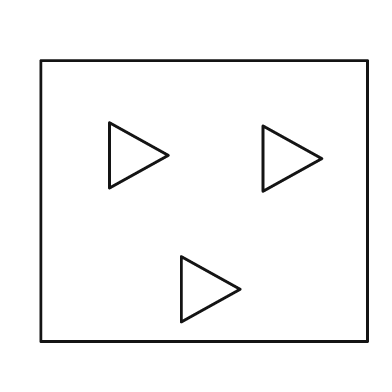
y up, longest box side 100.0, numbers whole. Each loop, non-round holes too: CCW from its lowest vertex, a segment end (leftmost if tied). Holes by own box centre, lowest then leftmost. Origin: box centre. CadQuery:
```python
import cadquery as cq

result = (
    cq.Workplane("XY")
    .moveTo(-50.0, -43.0)
    .lineTo(50.0, -43.0)
    .lineTo(50.0, 43.0)
    .lineTo(-50.0, 43.0)
    .close()
    .moveTo(-7.0, -37.0)
    .lineTo(11.0, -27.0)
    .lineTo(-7.0, -17.0)
    .close()
    .moveTo(18.0, 3.0)
    .lineTo(36.0, 13.0)
    .lineTo(18.0, 23.0)
    .close()
    .moveTo(-29.0, 4.0)
    .lineTo(-11.0, 14.0)
    .lineTo(-29.0, 24.0)
    .close()
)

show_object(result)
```